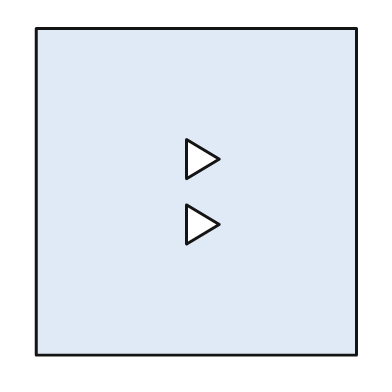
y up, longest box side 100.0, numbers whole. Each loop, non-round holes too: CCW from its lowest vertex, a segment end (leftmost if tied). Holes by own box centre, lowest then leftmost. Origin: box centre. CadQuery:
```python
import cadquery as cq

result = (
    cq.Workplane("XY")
    .moveTo(-49.0, -50.0)
    .lineTo(49.0, -50.0)
    .lineTo(49.0, 50.0)
    .lineTo(-49.0, 50.0)
    .close()
    .moveTo(-3.0, -16.0)
    .lineTo(7.0, -10.0)
    .lineTo(-3.0, -4.0)
    .close()
    .moveTo(-3.0, 4.0)
    .lineTo(7.0, 10.0)
    .lineTo(-3.0, 16.0)
    .close()
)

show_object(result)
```